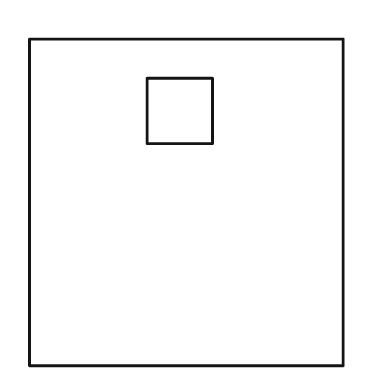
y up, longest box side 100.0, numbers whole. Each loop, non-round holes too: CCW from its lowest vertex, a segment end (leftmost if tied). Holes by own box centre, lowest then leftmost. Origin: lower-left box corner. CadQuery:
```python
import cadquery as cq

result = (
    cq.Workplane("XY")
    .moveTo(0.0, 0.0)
    .lineTo(96.0, 0.0)
    .lineTo(96.0, 100.0)
    .lineTo(0.0, 100.0)
    .close()
    .moveTo(36.0, 68.0)
    .lineTo(56.0, 68.0)
    .lineTo(56.0, 88.0)
    .lineTo(36.0, 88.0)
    .close()
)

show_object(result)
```